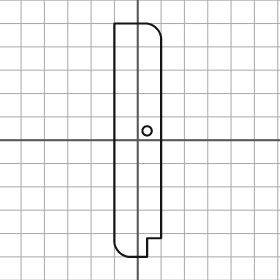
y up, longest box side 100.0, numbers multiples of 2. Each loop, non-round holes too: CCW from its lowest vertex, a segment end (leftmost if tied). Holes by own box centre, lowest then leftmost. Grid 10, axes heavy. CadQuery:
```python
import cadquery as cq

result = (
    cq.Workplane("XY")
    .moveTo(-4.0, -50.0)
    .lineTo(4.0, -50.0)
    .lineTo(4.0, -42.0)
    .lineTo(10.0, -42.0)
    .lineTo(10.0, 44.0)
    .threePointArc((8.0, 48.0), (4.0, 50.0))
    .lineTo(-10.0, 50.0)
    .lineTo(-10.0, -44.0)
    .threePointArc((-8.0, -48.0), (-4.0, -50.0))
    .close()
    .moveTo(4.0, 4.0)
    .circle(2.0)
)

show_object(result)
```